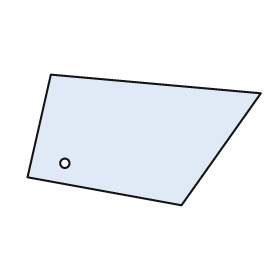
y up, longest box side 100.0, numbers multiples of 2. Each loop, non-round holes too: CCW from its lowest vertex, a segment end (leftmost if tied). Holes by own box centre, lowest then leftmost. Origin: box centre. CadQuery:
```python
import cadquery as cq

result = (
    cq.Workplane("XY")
    .moveTo(16.0, -28.0)
    .lineTo(50.0, 20.0)
    .lineTo(-40.0, 28.0)
    .lineTo(-50.0, -16.0)
    .close()
    .moveTo(-34.0, -10.0)
    .circle(2.0)
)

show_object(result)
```